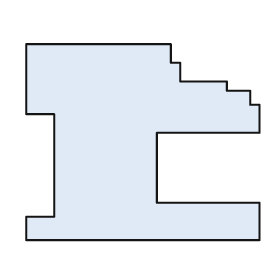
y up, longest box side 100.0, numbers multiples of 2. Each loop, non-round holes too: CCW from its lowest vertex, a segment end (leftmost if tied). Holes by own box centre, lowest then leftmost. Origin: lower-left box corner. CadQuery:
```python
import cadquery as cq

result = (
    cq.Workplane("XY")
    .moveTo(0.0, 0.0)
    .lineTo(100.0, 0.0)
    .lineTo(100.0, 16.0)
    .lineTo(56.0, 16.0)
    .lineTo(56.0, 46.0)
    .lineTo(100.0, 46.0)
    .lineTo(100.0, 58.0)
    .lineTo(96.0, 58.0)
    .lineTo(96.0, 64.0)
    .lineTo(86.0, 64.0)
    .lineTo(86.0, 68.0)
    .lineTo(66.0, 68.0)
    .lineTo(66.0, 76.0)
    .lineTo(62.0, 76.0)
    .lineTo(62.0, 84.0)
    .lineTo(0.0, 84.0)
    .lineTo(0.0, 54.0)
    .lineTo(12.0, 54.0)
    .lineTo(12.0, 10.0)
    .lineTo(0.0, 10.0)
    .close()
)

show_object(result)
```